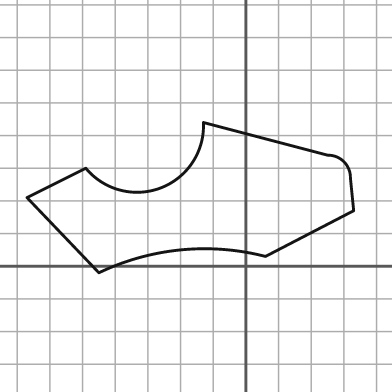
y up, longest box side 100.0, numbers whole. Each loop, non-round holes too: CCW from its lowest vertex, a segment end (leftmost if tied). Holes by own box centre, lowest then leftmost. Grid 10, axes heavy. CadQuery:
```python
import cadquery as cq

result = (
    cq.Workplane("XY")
    .moveTo(-45.0, -2.0)
    .threePointArc((-20.0, 5.0), (6.0, 3.0))
    .lineTo(33.0, 17.0)
    .lineTo(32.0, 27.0)
    .threePointArc((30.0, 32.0), (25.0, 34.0))
    .lineTo(-13.0, 44.0)
    .threePointArc((-26.0, 24.0), (-49.0, 30.0))
    .lineTo(-67.0, 21.0)
    .close()
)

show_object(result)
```